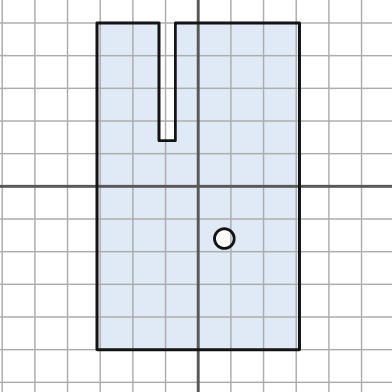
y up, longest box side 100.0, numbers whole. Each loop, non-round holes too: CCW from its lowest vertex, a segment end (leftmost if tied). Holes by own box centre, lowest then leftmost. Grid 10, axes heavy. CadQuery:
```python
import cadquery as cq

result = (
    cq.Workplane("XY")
    .moveTo(-31.0, -50.0)
    .lineTo(31.0, -50.0)
    .lineTo(31.0, 50.0)
    .lineTo(-7.0, 50.0)
    .lineTo(-7.0, 14.0)
    .lineTo(-12.0, 14.0)
    .lineTo(-12.0, 50.0)
    .lineTo(-31.0, 50.0)
    .close()
    .moveTo(8.0, -16.0)
    .circle(3.0)
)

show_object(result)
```